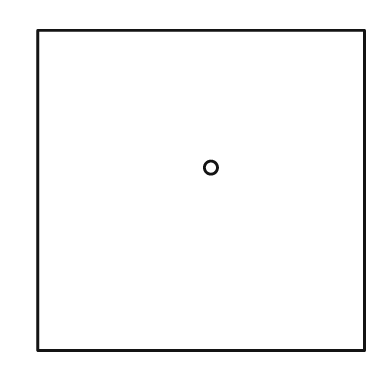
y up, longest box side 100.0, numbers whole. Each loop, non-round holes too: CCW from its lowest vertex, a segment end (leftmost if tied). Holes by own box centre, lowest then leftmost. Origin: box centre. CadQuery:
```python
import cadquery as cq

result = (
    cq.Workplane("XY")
    .moveTo(-50.0, -49.0)
    .lineTo(50.0, -49.0)
    .lineTo(50.0, 49.0)
    .lineTo(-50.0, 49.0)
    .close()
    .moveTo(3.0, 7.0)
    .circle(2.0)
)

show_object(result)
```